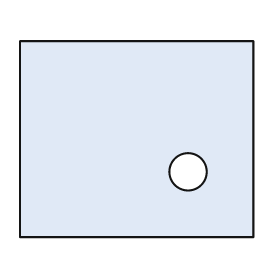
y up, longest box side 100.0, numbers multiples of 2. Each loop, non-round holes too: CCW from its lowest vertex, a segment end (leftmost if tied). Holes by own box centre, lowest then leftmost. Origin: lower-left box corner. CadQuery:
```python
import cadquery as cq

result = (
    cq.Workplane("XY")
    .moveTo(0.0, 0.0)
    .lineTo(100.0, 0.0)
    .lineTo(100.0, 84.0)
    .lineTo(0.0, 84.0)
    .close()
    .moveTo(72.0, 28.0)
    .circle(8.0)
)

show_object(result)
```